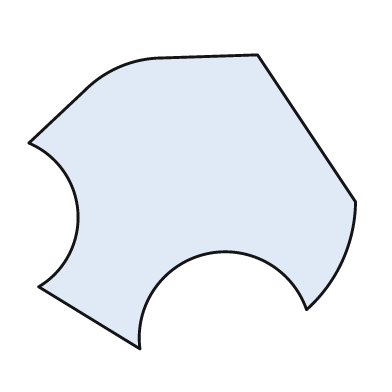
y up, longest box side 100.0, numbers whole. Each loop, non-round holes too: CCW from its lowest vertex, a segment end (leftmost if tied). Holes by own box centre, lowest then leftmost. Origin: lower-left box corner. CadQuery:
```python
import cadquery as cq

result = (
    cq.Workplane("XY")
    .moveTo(34.0, 0.0)
    .threePointArc((54.0, 29.0), (85.0, 12.0))
    .threePointArc((96.0, 27.0), (100.0, 45.0))
    .lineTo(70.0, 90.0)
    .lineTo(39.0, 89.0)
    .threePointArc((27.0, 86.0), (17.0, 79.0))
    .lineTo(0.0, 63.0)
    .threePointArc((15.0, 42.0), (3.0, 19.0))
    .close()
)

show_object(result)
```